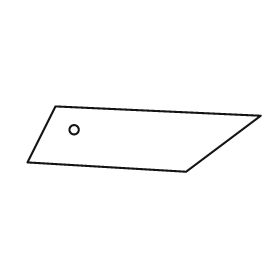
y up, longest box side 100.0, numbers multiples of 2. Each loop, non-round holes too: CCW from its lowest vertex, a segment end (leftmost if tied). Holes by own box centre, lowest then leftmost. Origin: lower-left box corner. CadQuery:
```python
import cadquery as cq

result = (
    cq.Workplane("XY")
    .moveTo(68.0, 0.0)
    .lineTo(100.0, 24.0)
    .lineTo(12.0, 28.0)
    .lineTo(0.0, 4.0)
    .close()
    .moveTo(20.0, 18.0)
    .circle(2.0)
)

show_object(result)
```